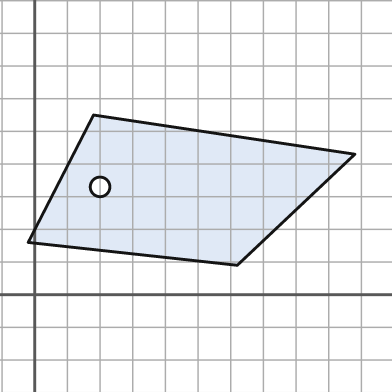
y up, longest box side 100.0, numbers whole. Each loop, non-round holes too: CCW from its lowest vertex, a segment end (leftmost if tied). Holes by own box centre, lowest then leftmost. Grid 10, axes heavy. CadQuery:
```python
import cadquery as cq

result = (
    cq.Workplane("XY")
    .moveTo(62.0, 9.0)
    .lineTo(98.0, 43.0)
    .lineTo(18.0, 55.0)
    .lineTo(-2.0, 16.0)
    .close()
    .moveTo(20.0, 33.0)
    .circle(3.0)
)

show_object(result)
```